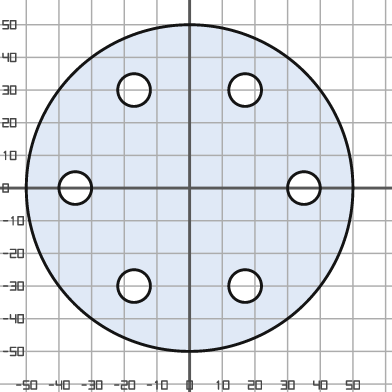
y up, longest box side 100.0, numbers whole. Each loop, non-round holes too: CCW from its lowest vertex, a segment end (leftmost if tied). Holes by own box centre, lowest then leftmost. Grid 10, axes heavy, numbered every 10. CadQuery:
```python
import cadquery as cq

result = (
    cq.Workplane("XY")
    .moveTo(0.0, 0.0)
    .circle(50.0)
    .moveTo(-17.0, -30.0)
    .circle(5.0)
    .moveTo(17.0, -30.0)
    .circle(5.0)
    .moveTo(-35.0, 0.0)
    .circle(5.0)
    .moveTo(35.0, 0.0)
    .circle(5.0)
    .moveTo(-17.0, 30.0)
    .circle(5.0)
    .moveTo(17.0, 30.0)
    .circle(5.0)
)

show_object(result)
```